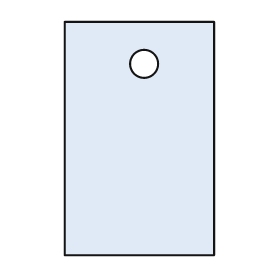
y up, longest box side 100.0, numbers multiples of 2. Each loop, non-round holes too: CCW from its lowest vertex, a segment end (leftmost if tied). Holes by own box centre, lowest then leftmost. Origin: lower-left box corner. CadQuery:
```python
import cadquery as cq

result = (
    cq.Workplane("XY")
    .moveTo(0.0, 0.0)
    .lineTo(64.0, 0.0)
    .lineTo(64.0, 100.0)
    .lineTo(0.0, 100.0)
    .close()
    .moveTo(34.0, 82.0)
    .circle(6.0)
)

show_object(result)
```